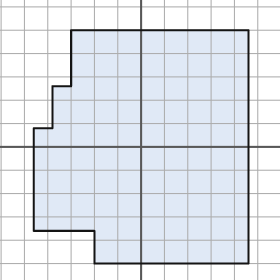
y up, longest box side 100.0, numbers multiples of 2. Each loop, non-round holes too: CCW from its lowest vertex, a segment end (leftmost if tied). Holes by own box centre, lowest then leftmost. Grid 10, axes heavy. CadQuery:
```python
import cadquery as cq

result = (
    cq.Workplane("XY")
    .moveTo(-20.0, -50.0)
    .lineTo(46.0, -50.0)
    .lineTo(46.0, 50.0)
    .lineTo(-30.0, 50.0)
    .lineTo(-30.0, 26.0)
    .lineTo(-38.0, 26.0)
    .lineTo(-38.0, 8.0)
    .lineTo(-46.0, 8.0)
    .lineTo(-46.0, -36.0)
    .lineTo(-20.0, -36.0)
    .close()
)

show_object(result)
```